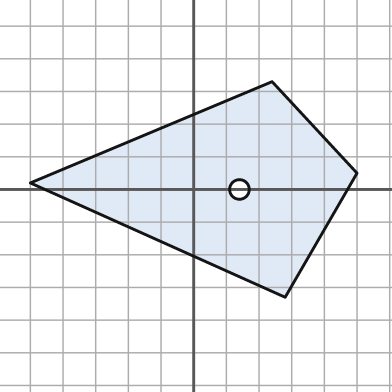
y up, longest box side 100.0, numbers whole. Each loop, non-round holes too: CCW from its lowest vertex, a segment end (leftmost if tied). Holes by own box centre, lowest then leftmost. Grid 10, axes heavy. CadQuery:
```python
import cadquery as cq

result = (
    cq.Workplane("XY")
    .moveTo(28.0, -33.0)
    .lineTo(50.0, 5.0)
    .lineTo(24.0, 33.0)
    .lineTo(-50.0, 2.0)
    .close()
    .moveTo(14.0, 0.0)
    .circle(3.0)
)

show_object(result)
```